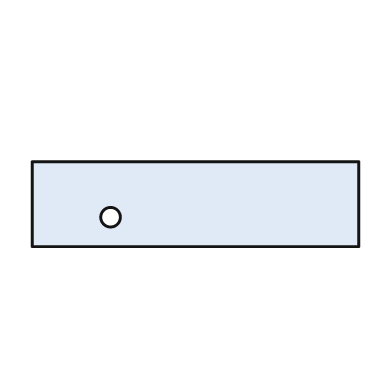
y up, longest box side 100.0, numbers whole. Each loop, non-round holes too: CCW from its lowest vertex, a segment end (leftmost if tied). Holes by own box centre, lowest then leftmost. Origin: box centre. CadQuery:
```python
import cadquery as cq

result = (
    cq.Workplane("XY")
    .moveTo(-50.0, -13.0)
    .lineTo(50.0, -13.0)
    .lineTo(50.0, 13.0)
    .lineTo(-50.0, 13.0)
    .close()
    .moveTo(-26.0, -4.0)
    .circle(3.0)
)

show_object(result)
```